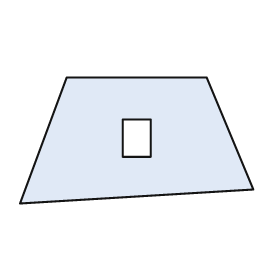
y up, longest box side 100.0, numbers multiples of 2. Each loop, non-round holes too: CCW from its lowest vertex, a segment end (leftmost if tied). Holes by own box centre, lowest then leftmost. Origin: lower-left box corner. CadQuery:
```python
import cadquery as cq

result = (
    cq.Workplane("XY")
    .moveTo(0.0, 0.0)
    .lineTo(100.0, 6.0)
    .lineTo(80.0, 54.0)
    .lineTo(20.0, 54.0)
    .close()
    .moveTo(44.0, 20.0)
    .lineTo(56.0, 20.0)
    .lineTo(56.0, 36.0)
    .lineTo(44.0, 36.0)
    .close()
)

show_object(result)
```